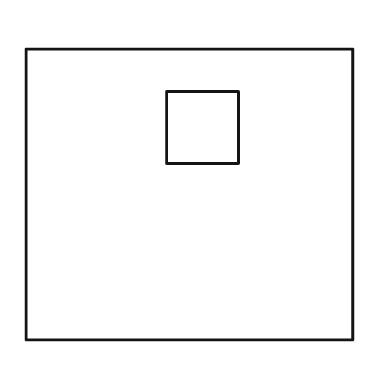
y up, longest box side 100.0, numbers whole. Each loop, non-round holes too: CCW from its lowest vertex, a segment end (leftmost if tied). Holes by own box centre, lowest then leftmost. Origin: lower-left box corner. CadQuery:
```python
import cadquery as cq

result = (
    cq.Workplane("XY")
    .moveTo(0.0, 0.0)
    .lineTo(100.0, 0.0)
    .lineTo(100.0, 89.0)
    .lineTo(0.0, 89.0)
    .close()
    .moveTo(43.0, 54.0)
    .lineTo(65.0, 54.0)
    .lineTo(65.0, 76.0)
    .lineTo(43.0, 76.0)
    .close()
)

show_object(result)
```